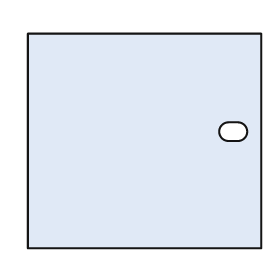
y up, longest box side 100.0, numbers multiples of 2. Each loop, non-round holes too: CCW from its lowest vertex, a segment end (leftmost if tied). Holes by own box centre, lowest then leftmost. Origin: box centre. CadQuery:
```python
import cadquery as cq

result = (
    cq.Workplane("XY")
    .moveTo(-50.0, -46.0)
    .lineTo(50.0, -46.0)
    .lineTo(50.0, 46.0)
    .lineTo(-50.0, 46.0)
    .close()
    .moveTo(36.0, 0.0)
    .lineTo(40.0, 0.0)
    .threePointArc((44.0, 4.0), (40.0, 8.0))
    .lineTo(36.0, 8.0)
    .threePointArc((32.0, 4.0), (36.0, 0.0))
    .close()
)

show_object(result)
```